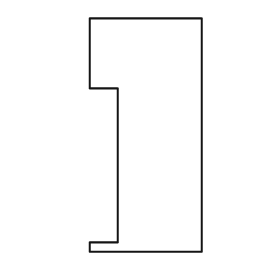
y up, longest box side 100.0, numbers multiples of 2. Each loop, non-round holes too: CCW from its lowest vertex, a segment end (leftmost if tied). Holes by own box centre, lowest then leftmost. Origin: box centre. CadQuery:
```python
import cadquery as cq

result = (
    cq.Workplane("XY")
    .moveTo(-24.0, -50.0)
    .lineTo(24.0, -50.0)
    .lineTo(24.0, 50.0)
    .lineTo(-24.0, 50.0)
    .lineTo(-24.0, 20.0)
    .lineTo(-12.0, 20.0)
    .lineTo(-12.0, -46.0)
    .lineTo(-24.0, -46.0)
    .close()
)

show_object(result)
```